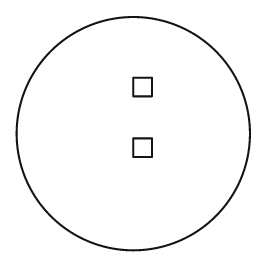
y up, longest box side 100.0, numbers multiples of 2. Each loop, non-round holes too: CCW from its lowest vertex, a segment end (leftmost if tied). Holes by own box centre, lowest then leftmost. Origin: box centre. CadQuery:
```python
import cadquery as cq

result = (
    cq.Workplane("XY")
    .moveTo(0.0, 0.0)
    .circle(50.0)
    .moveTo(0.0, -10.0)
    .lineTo(8.0, -10.0)
    .lineTo(8.0, -2.0)
    .lineTo(0.0, -2.0)
    .close()
    .moveTo(0.0, 16.0)
    .lineTo(8.0, 16.0)
    .lineTo(8.0, 24.0)
    .lineTo(0.0, 24.0)
    .close()
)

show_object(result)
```